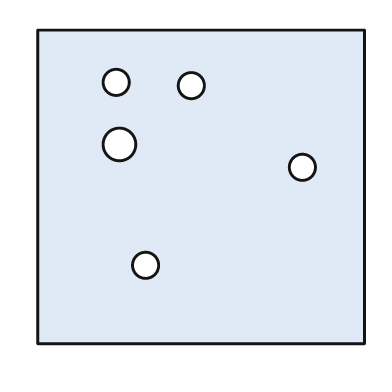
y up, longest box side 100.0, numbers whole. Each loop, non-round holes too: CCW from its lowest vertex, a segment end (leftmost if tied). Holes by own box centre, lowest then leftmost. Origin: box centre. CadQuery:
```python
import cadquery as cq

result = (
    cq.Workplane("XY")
    .moveTo(-50.0, -48.0)
    .lineTo(50.0, -48.0)
    .lineTo(50.0, 48.0)
    .lineTo(-50.0, 48.0)
    .close()
    .moveTo(-17.0, -24.0)
    .circle(4.0)
    .moveTo(31.0, 6.0)
    .circle(4.0)
    .moveTo(-25.0, 13.0)
    .circle(5.0)
    .moveTo(-3.0, 31.0)
    .circle(4.0)
    .moveTo(-26.0, 32.0)
    .circle(4.0)
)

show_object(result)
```